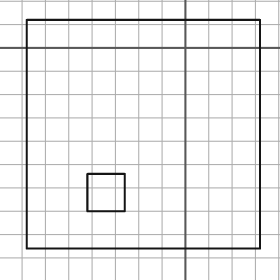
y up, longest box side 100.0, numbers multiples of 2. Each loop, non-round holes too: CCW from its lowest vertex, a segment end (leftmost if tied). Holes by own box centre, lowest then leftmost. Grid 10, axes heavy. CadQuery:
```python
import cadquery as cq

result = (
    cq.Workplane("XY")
    .moveTo(-68.0, -86.0)
    .lineTo(32.0, -86.0)
    .lineTo(32.0, 12.0)
    .lineTo(-68.0, 12.0)
    .close()
    .moveTo(-42.0, -70.0)
    .lineTo(-26.0, -70.0)
    .lineTo(-26.0, -54.0)
    .lineTo(-42.0, -54.0)
    .close()
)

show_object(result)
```